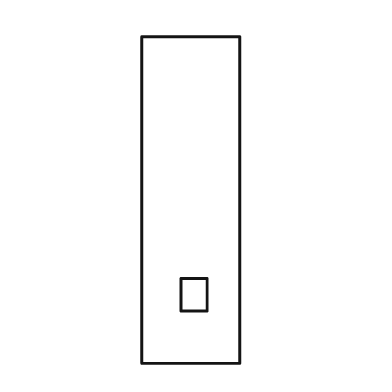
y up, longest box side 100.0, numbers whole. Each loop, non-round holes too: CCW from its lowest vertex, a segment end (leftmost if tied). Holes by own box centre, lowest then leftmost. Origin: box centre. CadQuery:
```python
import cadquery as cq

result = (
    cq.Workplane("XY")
    .moveTo(-15.0, -50.0)
    .lineTo(15.0, -50.0)
    .lineTo(15.0, 50.0)
    .lineTo(-15.0, 50.0)
    .close()
    .moveTo(-3.0, -34.0)
    .lineTo(5.0, -34.0)
    .lineTo(5.0, -24.0)
    .lineTo(-3.0, -24.0)
    .close()
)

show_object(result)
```